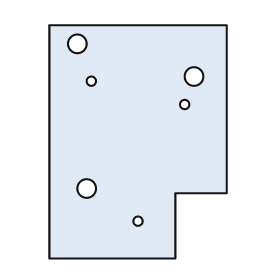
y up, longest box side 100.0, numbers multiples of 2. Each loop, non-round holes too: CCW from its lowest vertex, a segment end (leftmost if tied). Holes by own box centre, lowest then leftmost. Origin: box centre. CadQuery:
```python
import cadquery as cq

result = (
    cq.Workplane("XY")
    .moveTo(-38.0, -50.0)
    .lineTo(16.0, -50.0)
    .lineTo(16.0, -22.0)
    .lineTo(38.0, -22.0)
    .lineTo(38.0, 50.0)
    .lineTo(-38.0, 50.0)
    .close()
    .moveTo(0.0, -34.0)
    .circle(2.0)
    .moveTo(-22.0, -20.0)
    .circle(4.0)
    .moveTo(20.0, 16.0)
    .circle(2.0)
    .moveTo(-20.0, 26.0)
    .circle(2.0)
    .moveTo(24.0, 28.0)
    .circle(4.0)
    .moveTo(-26.0, 42.0)
    .circle(4.0)
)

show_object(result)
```